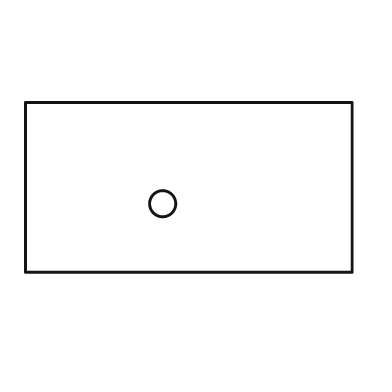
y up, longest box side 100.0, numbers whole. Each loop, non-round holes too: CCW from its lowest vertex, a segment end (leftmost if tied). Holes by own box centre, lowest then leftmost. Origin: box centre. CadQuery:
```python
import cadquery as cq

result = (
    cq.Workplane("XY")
    .moveTo(-50.0, -26.0)
    .lineTo(50.0, -26.0)
    .lineTo(50.0, 26.0)
    .lineTo(-50.0, 26.0)
    .close()
    .moveTo(-8.0, -5.0)
    .circle(4.0)
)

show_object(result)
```